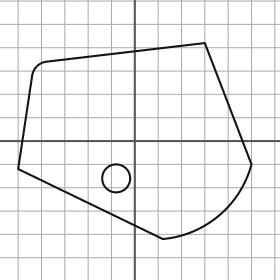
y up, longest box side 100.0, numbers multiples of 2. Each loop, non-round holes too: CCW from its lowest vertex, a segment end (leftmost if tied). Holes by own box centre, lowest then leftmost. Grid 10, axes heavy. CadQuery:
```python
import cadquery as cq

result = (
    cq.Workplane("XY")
    .moveTo(12.0, -42.0)
    .threePointArc((36.0, -32.0), (50.0, -10.0))
    .lineTo(30.0, 42.0)
    .lineTo(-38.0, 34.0)
    .threePointArc((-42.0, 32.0), (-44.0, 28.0))
    .lineTo(-50.0, -12.0)
    .close()
    .moveTo(-8.0, -16.0)
    .circle(6.0)
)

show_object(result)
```